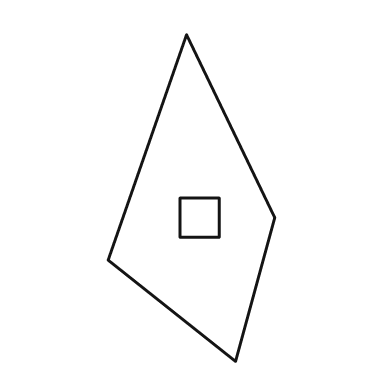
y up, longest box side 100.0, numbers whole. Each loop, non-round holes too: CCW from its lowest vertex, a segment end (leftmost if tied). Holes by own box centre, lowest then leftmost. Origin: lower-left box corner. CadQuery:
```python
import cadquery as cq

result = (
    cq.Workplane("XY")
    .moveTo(39.0, 0.0)
    .lineTo(51.0, 44.0)
    .lineTo(24.0, 100.0)
    .lineTo(0.0, 31.0)
    .close()
    .moveTo(22.0, 38.0)
    .lineTo(34.0, 38.0)
    .lineTo(34.0, 50.0)
    .lineTo(22.0, 50.0)
    .close()
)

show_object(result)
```